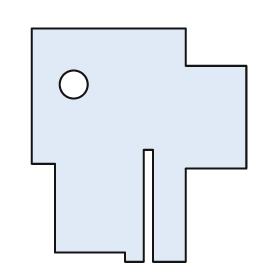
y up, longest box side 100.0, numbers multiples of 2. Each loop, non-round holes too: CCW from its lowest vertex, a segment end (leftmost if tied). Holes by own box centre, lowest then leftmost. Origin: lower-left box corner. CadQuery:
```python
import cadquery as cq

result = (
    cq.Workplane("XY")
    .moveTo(40.0, 0.0)
    .lineTo(48.0, 0.0)
    .lineTo(48.0, 48.0)
    .lineTo(52.0, 48.0)
    .lineTo(52.0, 0.0)
    .lineTo(66.0, 0.0)
    .lineTo(66.0, 40.0)
    .lineTo(92.0, 40.0)
    .lineTo(92.0, 84.0)
    .lineTo(66.0, 84.0)
    .lineTo(66.0, 100.0)
    .lineTo(0.0, 100.0)
    .lineTo(0.0, 42.0)
    .lineTo(10.0, 42.0)
    .lineTo(10.0, 4.0)
    .lineTo(40.0, 4.0)
    .close()
    .moveTo(18.0, 76.0)
    .circle(6.0)
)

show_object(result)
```